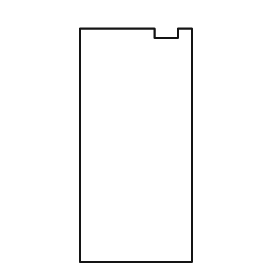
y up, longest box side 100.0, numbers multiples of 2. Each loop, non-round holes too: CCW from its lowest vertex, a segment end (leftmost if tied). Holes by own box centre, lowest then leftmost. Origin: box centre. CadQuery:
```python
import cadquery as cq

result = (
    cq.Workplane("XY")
    .moveTo(-24.0, -50.0)
    .lineTo(24.0, -50.0)
    .lineTo(24.0, 50.0)
    .lineTo(18.0, 50.0)
    .lineTo(18.0, 46.0)
    .lineTo(8.0, 46.0)
    .lineTo(8.0, 50.0)
    .lineTo(-24.0, 50.0)
    .close()
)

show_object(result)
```